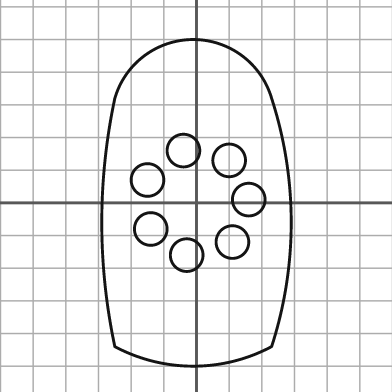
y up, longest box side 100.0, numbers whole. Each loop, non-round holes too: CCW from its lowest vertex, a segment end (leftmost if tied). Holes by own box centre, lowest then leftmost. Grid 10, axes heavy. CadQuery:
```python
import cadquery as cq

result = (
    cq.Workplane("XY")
    .moveTo(-25.0, -44.0)
    .threePointArc((-1.0, -50.0), (23.0, -44.0))
    .threePointArc((29.0, -6.0), (23.0, 32.0))
    .threePointArc((-1.0, 50.0), (-25.0, 32.0))
    .threePointArc((-29.0, -6.0), (-25.0, -44.0))
    .close()
    .moveTo(-3.0, -16.0)
    .circle(5.0)
    .moveTo(11.0, -12.0)
    .circle(5.0)
    .moveTo(-14.0, -8.0)
    .circle(5.0)
    .moveTo(16.0, 1.0)
    .circle(5.0)
    .moveTo(-15.0, 7.0)
    .circle(5.0)
    .moveTo(10.0, 13.0)
    .circle(5.0)
    .moveTo(-4.0, 16.0)
    .circle(5.0)
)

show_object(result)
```